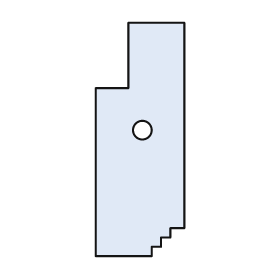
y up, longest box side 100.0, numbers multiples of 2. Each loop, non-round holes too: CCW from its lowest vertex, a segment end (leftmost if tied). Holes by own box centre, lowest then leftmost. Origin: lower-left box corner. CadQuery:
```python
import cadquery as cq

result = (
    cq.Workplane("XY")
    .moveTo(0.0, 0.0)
    .lineTo(24.0, 0.0)
    .lineTo(24.0, 4.0)
    .lineTo(28.0, 4.0)
    .lineTo(28.0, 8.0)
    .lineTo(32.0, 8.0)
    .lineTo(32.0, 12.0)
    .lineTo(38.0, 12.0)
    .lineTo(38.0, 100.0)
    .lineTo(14.0, 100.0)
    .lineTo(14.0, 72.0)
    .lineTo(0.0, 72.0)
    .close()
    .moveTo(20.0, 54.0)
    .circle(4.0)
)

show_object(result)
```